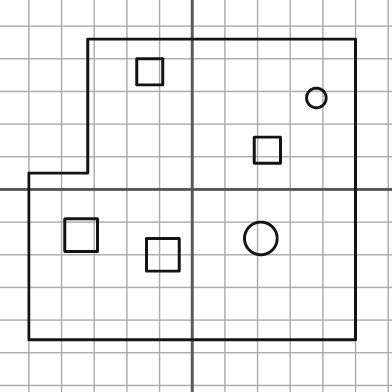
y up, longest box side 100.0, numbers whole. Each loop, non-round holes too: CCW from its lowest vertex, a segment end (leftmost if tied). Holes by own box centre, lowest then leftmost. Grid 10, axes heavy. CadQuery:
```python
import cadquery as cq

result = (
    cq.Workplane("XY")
    .moveTo(-50.0, -46.0)
    .lineTo(50.0, -46.0)
    .lineTo(50.0, 46.0)
    .lineTo(-32.0, 46.0)
    .lineTo(-32.0, 5.0)
    .lineTo(-50.0, 5.0)
    .close()
    .moveTo(-14.0, -25.0)
    .lineTo(-4.0, -25.0)
    .lineTo(-4.0, -15.0)
    .lineTo(-14.0, -15.0)
    .close()
    .moveTo(21.0, -15.0)
    .circle(5.0)
    .moveTo(-39.0, -19.0)
    .lineTo(-29.0, -19.0)
    .lineTo(-29.0, -9.0)
    .lineTo(-39.0, -9.0)
    .close()
    .moveTo(19.0, 8.0)
    .lineTo(27.0, 8.0)
    .lineTo(27.0, 16.0)
    .lineTo(19.0, 16.0)
    .close()
    .moveTo(38.0, 28.0)
    .circle(3.0)
    .moveTo(-17.0, 32.0)
    .lineTo(-9.0, 32.0)
    .lineTo(-9.0, 40.0)
    .lineTo(-17.0, 40.0)
    .close()
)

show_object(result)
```